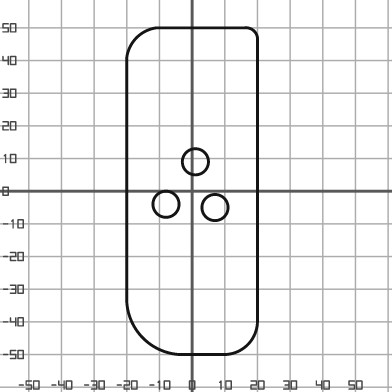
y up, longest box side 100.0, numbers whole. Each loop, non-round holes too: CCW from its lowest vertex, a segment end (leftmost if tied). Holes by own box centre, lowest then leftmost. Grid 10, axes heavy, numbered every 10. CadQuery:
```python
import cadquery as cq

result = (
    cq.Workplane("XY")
    .moveTo(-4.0, -50.0)
    .lineTo(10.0, -50.0)
    .threePointArc((17.0, -47.0), (20.0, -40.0))
    .lineTo(20.0, 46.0)
    .threePointArc((19.0, 49.0), (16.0, 50.0))
    .lineTo(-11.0, 50.0)
    .threePointArc((-17.0, 47.0), (-20.0, 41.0))
    .lineTo(-20.0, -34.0)
    .threePointArc((-15.0, -45.0), (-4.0, -50.0))
    .close()
    .moveTo(7.0, -5.0)
    .circle(4.0)
    .moveTo(-8.0, -4.0)
    .circle(4.0)
    .moveTo(1.0, 9.0)
    .circle(4.0)
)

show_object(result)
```